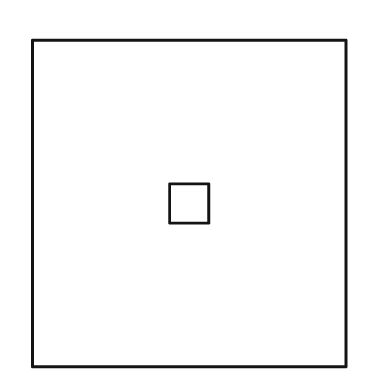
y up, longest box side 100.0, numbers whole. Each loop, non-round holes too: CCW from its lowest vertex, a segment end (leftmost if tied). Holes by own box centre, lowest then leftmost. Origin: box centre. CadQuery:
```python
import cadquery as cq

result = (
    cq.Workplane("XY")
    .moveTo(-48.0, -50.0)
    .lineTo(48.0, -50.0)
    .lineTo(48.0, 50.0)
    .lineTo(-48.0, 50.0)
    .close()
    .moveTo(-6.0, -6.0)
    .lineTo(6.0, -6.0)
    .lineTo(6.0, 6.0)
    .lineTo(-6.0, 6.0)
    .close()
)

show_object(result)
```